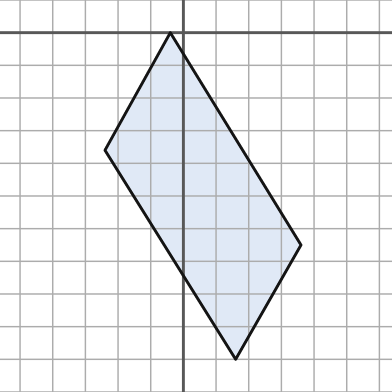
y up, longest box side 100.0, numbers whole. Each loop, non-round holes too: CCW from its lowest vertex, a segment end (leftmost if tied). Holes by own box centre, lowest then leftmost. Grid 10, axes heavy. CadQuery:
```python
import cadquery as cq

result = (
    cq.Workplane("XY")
    .moveTo(16.0, -100.0)
    .lineTo(36.0, -65.0)
    .lineTo(-4.0, 0.0)
    .lineTo(-24.0, -36.0)
    .close()
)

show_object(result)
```